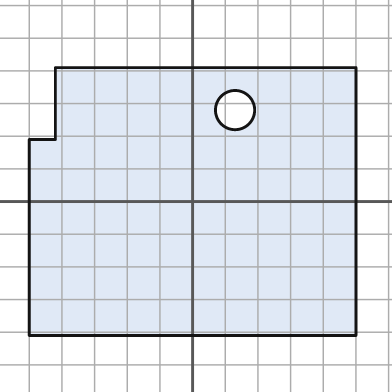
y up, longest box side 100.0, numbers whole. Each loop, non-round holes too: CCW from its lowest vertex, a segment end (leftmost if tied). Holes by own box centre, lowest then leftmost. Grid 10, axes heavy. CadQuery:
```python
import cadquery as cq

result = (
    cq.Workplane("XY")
    .moveTo(-50.0, -41.0)
    .lineTo(50.0, -41.0)
    .lineTo(50.0, 41.0)
    .lineTo(-42.0, 41.0)
    .lineTo(-42.0, 19.0)
    .lineTo(-50.0, 19.0)
    .close()
    .moveTo(13.0, 28.0)
    .circle(6.0)
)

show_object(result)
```